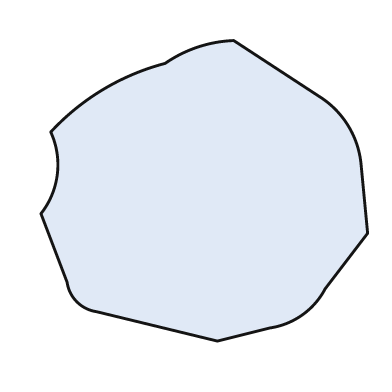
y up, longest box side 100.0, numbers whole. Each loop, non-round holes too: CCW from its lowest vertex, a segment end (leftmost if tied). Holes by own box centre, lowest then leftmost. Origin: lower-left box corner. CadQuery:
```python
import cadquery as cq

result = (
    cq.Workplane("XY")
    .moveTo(54.0, 0.0)
    .lineTo(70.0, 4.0)
    .threePointArc((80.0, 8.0), (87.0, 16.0))
    .lineTo(100.0, 33.0)
    .lineTo(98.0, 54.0)
    .threePointArc((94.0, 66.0), (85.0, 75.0))
    .lineTo(59.0, 92.0)
    .threePointArc((48.0, 90.0), (38.0, 85.0))
    .threePointArc((19.0, 77.0), (3.0, 64.0))
    .threePointArc((5.0, 51.0), (0.0, 39.0))
    .lineTo(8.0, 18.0)
    .threePointArc((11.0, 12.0), (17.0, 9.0))
    .close()
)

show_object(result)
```